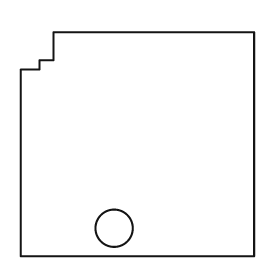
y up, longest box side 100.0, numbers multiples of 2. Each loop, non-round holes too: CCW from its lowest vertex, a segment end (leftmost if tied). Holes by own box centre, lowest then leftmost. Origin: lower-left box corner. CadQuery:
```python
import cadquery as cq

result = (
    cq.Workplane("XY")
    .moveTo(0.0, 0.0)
    .lineTo(100.0, 0.0)
    .lineTo(100.0, 96.0)
    .lineTo(14.0, 96.0)
    .lineTo(14.0, 84.0)
    .lineTo(8.0, 84.0)
    .lineTo(8.0, 80.0)
    .lineTo(0.0, 80.0)
    .close()
    .moveTo(40.0, 12.0)
    .circle(8.0)
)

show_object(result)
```